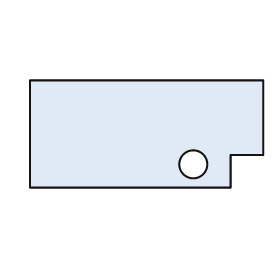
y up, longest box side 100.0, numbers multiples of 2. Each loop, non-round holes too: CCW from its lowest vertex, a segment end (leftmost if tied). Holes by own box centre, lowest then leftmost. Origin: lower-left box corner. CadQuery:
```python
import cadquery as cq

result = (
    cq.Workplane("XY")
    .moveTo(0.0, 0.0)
    .lineTo(86.0, 0.0)
    .lineTo(86.0, 14.0)
    .lineTo(100.0, 14.0)
    .lineTo(100.0, 46.0)
    .lineTo(0.0, 46.0)
    .close()
    .moveTo(70.0, 10.0)
    .circle(6.0)
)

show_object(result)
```